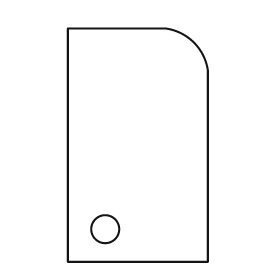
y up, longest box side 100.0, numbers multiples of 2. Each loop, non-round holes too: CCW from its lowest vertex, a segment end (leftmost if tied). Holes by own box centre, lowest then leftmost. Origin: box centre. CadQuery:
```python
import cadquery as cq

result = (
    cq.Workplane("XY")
    .moveTo(-30.0, -50.0)
    .lineTo(30.0, -50.0)
    .lineTo(30.0, 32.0)
    .threePointArc((24.0, 44.0), (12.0, 50.0))
    .lineTo(-30.0, 50.0)
    .close()
    .moveTo(-14.0, -36.0)
    .circle(6.0)
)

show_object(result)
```